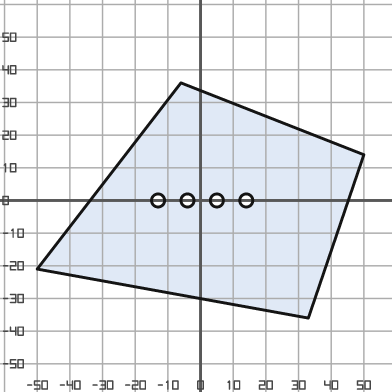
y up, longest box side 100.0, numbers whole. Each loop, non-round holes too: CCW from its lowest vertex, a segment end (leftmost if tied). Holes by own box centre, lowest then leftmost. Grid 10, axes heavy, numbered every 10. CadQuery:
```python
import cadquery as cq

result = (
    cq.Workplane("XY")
    .moveTo(33.0, -36.0)
    .lineTo(50.0, 14.0)
    .lineTo(-6.0, 36.0)
    .lineTo(-50.0, -21.0)
    .close()
    .moveTo(-13.0, 0.0)
    .circle(2.0)
    .moveTo(-4.0, 0.0)
    .circle(2.0)
    .moveTo(5.0, 0.0)
    .circle(2.0)
    .moveTo(14.0, 0.0)
    .circle(2.0)
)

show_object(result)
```